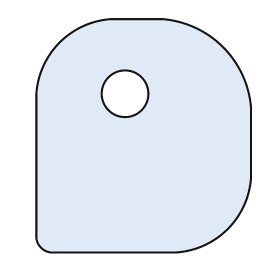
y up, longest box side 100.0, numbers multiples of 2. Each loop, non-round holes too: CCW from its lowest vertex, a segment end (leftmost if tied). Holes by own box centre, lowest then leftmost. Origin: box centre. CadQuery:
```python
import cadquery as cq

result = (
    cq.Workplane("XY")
    .moveTo(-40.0, -50.0)
    .lineTo(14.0, -50.0)
    .threePointArc((36.0, -40.0), (46.0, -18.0))
    .lineTo(46.0, 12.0)
    .threePointArc((34.0, 38.0), (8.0, 50.0))
    .lineTo(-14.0, 50.0)
    .threePointArc((-36.0, 40.0), (-46.0, 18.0))
    .lineTo(-46.0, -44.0)
    .threePointArc((-44.0, -48.0), (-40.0, -50.0))
    .close()
    .moveTo(-8.0, 18.0)
    .circle(10.0)
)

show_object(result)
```